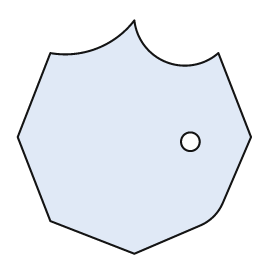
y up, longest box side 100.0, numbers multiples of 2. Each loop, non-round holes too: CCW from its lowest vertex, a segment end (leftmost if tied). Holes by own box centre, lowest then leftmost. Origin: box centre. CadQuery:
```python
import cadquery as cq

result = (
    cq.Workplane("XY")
    .moveTo(0.0, -50.0)
    .lineTo(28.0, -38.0)
    .threePointArc((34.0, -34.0), (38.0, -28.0))
    .lineTo(50.0, 0.0)
    .lineTo(36.0, 36.0)
    .threePointArc((14.0, 32.0), (0.0, 50.0))
    .threePointArc((-16.0, 38.0), (-36.0, 36.0))
    .lineTo(-50.0, 0.0)
    .lineTo(-36.0, -36.0)
    .close()
    .moveTo(24.0, -2.0)
    .circle(4.0)
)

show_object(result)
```